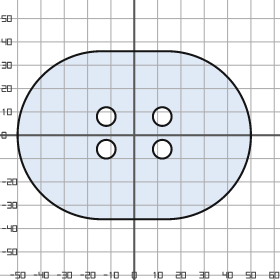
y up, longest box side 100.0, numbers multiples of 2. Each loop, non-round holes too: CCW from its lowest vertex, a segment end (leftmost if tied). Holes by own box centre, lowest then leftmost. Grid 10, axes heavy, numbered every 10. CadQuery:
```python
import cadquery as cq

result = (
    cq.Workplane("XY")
    .moveTo(-14.0, -36.0)
    .lineTo(14.0, -36.0)
    .threePointArc((50.0, 0.0), (14.0, 36.0))
    .lineTo(-14.0, 36.0)
    .threePointArc((-50.0, 0.0), (-14.0, -36.0))
    .close()
    .moveTo(-12.0, -6.0)
    .circle(4.0)
    .moveTo(12.0, -6.0)
    .circle(4.0)
    .moveTo(-12.0, 8.0)
    .circle(4.0)
    .moveTo(12.0, 8.0)
    .circle(4.0)
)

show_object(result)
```